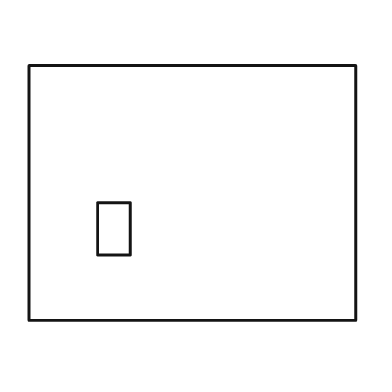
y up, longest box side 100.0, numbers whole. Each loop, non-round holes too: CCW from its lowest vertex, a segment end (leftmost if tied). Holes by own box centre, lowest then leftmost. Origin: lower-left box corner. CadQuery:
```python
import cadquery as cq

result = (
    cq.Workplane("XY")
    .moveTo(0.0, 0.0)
    .lineTo(100.0, 0.0)
    .lineTo(100.0, 78.0)
    .lineTo(0.0, 78.0)
    .close()
    .moveTo(21.0, 20.0)
    .lineTo(31.0, 20.0)
    .lineTo(31.0, 36.0)
    .lineTo(21.0, 36.0)
    .close()
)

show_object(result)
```